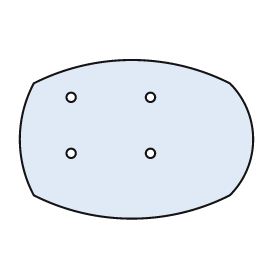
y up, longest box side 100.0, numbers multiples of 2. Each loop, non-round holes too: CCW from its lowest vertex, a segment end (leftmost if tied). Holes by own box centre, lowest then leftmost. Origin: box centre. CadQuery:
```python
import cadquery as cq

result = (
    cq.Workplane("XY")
    .moveTo(-44.0, -24.0)
    .threePointArc((-2.0, -34.0), (40.0, -24.0))
    .threePointArc((50.0, 0.0), (40.0, 24.0))
    .threePointArc((-2.0, 34.0), (-44.0, 24.0))
    .threePointArc((-50.0, 0.0), (-44.0, -24.0))
    .close()
    .moveTo(-28.0, -6.0)
    .circle(2.0)
    .moveTo(6.0, -6.0)
    .circle(2.0)
    .moveTo(-28.0, 18.0)
    .circle(2.0)
    .moveTo(6.0, 18.0)
    .circle(2.0)
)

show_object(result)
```